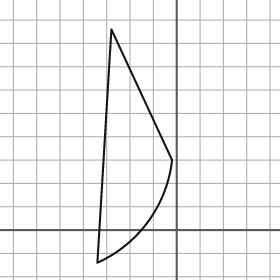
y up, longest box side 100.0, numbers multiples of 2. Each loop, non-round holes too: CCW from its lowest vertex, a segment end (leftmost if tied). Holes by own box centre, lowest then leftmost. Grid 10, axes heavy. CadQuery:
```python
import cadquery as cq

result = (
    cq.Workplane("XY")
    .moveTo(-34.0, -14.0)
    .threePointArc((-12.0, 4.0), (-2.0, 30.0))
    .lineTo(-28.0, 86.0)
    .close()
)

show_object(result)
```